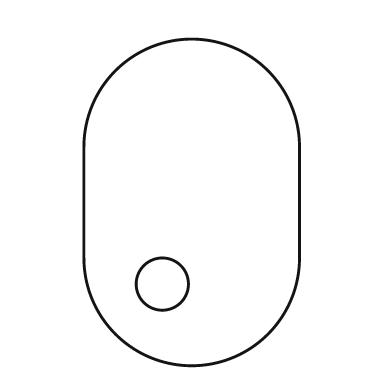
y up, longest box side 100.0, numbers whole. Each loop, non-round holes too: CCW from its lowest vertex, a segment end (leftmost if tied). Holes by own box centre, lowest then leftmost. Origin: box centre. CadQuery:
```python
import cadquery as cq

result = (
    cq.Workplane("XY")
    .moveTo(-33.0, -17.0)
    .threePointArc((0.0, -50.0), (33.0, -17.0))
    .lineTo(33.0, 17.0)
    .threePointArc((0.0, 50.0), (-33.0, 17.0))
    .close()
    .moveTo(-9.0, -25.0)
    .circle(8.0)
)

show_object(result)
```